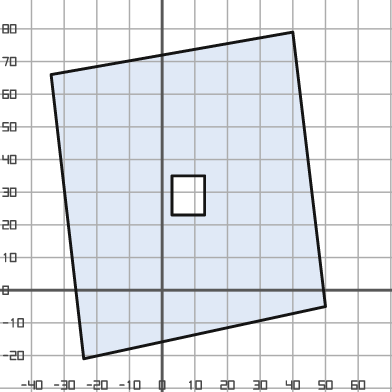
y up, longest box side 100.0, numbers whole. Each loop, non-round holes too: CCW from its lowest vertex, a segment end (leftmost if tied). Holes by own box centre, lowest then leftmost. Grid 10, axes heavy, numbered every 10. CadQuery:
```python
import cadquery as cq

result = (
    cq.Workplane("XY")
    .moveTo(-24.0, -21.0)
    .lineTo(50.0, -5.0)
    .lineTo(40.0, 79.0)
    .lineTo(-34.0, 66.0)
    .close()
    .moveTo(3.0, 23.0)
    .lineTo(13.0, 23.0)
    .lineTo(13.0, 35.0)
    .lineTo(3.0, 35.0)
    .close()
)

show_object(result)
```